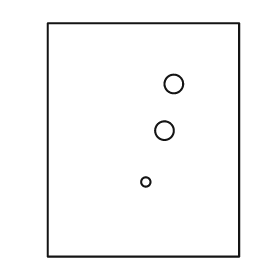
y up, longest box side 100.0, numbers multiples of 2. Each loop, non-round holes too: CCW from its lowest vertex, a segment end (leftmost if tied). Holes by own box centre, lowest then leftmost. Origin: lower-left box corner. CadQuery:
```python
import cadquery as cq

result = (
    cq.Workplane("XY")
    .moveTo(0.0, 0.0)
    .lineTo(82.0, 0.0)
    .lineTo(82.0, 100.0)
    .lineTo(0.0, 100.0)
    .close()
    .moveTo(42.0, 32.0)
    .circle(2.0)
    .moveTo(50.0, 54.0)
    .circle(4.0)
    .moveTo(54.0, 74.0)
    .circle(4.0)
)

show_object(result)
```